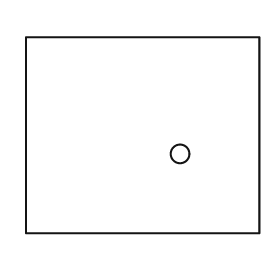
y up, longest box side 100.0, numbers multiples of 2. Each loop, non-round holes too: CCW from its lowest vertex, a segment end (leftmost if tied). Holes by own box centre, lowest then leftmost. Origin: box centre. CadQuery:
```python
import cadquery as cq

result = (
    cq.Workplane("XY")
    .moveTo(-50.0, -42.0)
    .lineTo(50.0, -42.0)
    .lineTo(50.0, 42.0)
    .lineTo(-50.0, 42.0)
    .close()
    .moveTo(16.0, -8.0)
    .circle(4.0)
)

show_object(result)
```